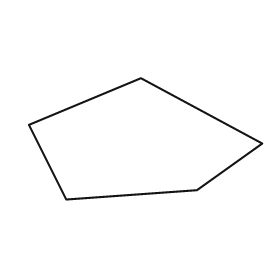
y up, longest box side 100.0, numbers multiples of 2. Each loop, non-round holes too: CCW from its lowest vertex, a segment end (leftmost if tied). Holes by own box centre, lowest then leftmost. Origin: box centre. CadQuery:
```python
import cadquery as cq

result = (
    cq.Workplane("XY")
    .moveTo(-34.0, -26.0)
    .lineTo(22.0, -22.0)
    .lineTo(50.0, -2.0)
    .lineTo(-2.0, 26.0)
    .lineTo(-50.0, 6.0)
    .close()
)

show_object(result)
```